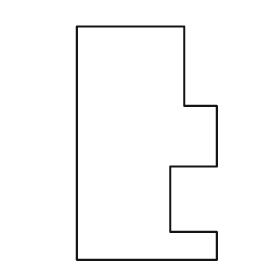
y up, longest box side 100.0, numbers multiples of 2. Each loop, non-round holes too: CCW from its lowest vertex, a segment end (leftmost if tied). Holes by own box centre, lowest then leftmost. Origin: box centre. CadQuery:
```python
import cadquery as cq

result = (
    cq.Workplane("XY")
    .moveTo(-30.0, -50.0)
    .lineTo(30.0, -50.0)
    .lineTo(30.0, -38.0)
    .lineTo(10.0, -38.0)
    .lineTo(10.0, -10.0)
    .lineTo(30.0, -10.0)
    .lineTo(30.0, 16.0)
    .lineTo(16.0, 16.0)
    .lineTo(16.0, 50.0)
    .lineTo(-30.0, 50.0)
    .close()
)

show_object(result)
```